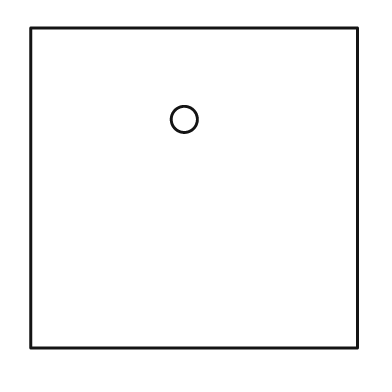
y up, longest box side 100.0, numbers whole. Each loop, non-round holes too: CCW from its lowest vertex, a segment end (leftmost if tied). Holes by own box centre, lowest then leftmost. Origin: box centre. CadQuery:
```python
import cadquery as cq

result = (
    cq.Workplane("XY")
    .moveTo(-50.0, -49.0)
    .lineTo(50.0, -49.0)
    .lineTo(50.0, 49.0)
    .lineTo(-50.0, 49.0)
    .close()
    .moveTo(-3.0, 21.0)
    .circle(4.0)
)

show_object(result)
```